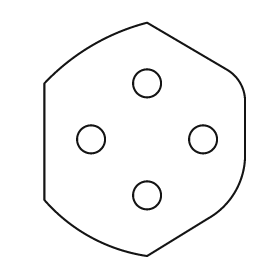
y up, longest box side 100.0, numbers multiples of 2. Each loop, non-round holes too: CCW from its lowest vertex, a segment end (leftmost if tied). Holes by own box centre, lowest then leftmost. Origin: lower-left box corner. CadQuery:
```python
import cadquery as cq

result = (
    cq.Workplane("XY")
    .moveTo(44.0, 0.0)
    .lineTo(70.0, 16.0)
    .threePointArc((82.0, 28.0), (86.0, 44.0))
    .lineTo(86.0, 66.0)
    .threePointArc((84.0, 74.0), (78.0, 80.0))
    .lineTo(44.0, 100.0)
    .threePointArc((20.0, 90.0), (0.0, 74.0))
    .lineTo(0.0, 24.0)
    .threePointArc((20.0, 8.0), (44.0, 0.0))
    .close()
    .moveTo(44.0, 26.0)
    .circle(6.0)
    .moveTo(20.0, 50.0)
    .circle(6.0)
    .moveTo(68.0, 50.0)
    .circle(6.0)
    .moveTo(44.0, 74.0)
    .circle(6.0)
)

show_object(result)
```